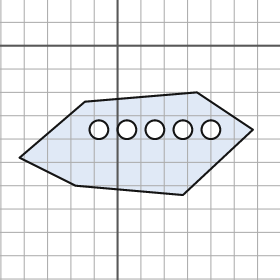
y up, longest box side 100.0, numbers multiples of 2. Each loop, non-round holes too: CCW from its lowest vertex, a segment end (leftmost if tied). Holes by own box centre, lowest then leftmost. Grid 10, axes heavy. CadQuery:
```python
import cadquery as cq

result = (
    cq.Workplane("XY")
    .moveTo(28.0, -64.0)
    .lineTo(58.0, -36.0)
    .lineTo(34.0, -20.0)
    .lineTo(-14.0, -24.0)
    .lineTo(-42.0, -48.0)
    .lineTo(-18.0, -60.0)
    .close()
    .moveTo(-8.0, -36.0)
    .circle(4.0)
    .moveTo(4.0, -36.0)
    .circle(4.0)
    .moveTo(16.0, -36.0)
    .circle(4.0)
    .moveTo(28.0, -36.0)
    .circle(4.0)
    .moveTo(40.0, -36.0)
    .circle(4.0)
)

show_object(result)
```